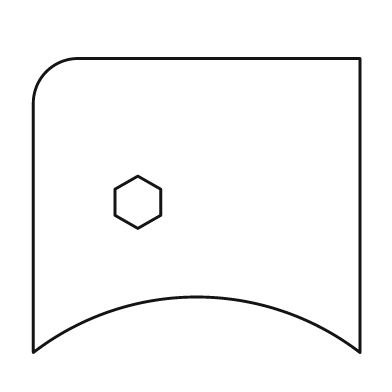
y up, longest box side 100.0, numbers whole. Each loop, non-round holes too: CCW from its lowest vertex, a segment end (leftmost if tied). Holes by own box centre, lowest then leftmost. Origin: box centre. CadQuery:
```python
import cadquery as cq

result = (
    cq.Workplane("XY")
    .moveTo(-50.0, -45.0)
    .threePointArc((0.0, -28.0), (50.0, -45.0))
    .lineTo(50.0, 45.0)
    .lineTo(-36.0, 45.0)
    .threePointArc((-46.0, 41.0), (-50.0, 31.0))
    .close()
    .moveTo(-18.0, -7.0)
    .lineTo(-11.0, -3.0)
    .lineTo(-11.0, 5.0)
    .lineTo(-18.0, 9.0)
    .lineTo(-25.0, 5.0)
    .lineTo(-25.0, -3.0)
    .close()
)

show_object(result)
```